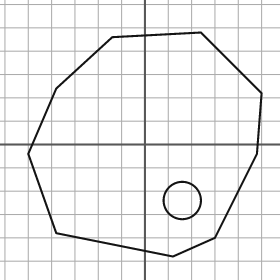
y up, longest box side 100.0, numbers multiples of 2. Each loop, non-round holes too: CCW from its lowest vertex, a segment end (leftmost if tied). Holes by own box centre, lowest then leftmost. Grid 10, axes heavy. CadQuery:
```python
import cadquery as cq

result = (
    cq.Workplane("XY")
    .moveTo(12.0, -48.0)
    .lineTo(30.0, -40.0)
    .lineTo(48.0, -4.0)
    .lineTo(50.0, 22.0)
    .lineTo(24.0, 48.0)
    .lineTo(-14.0, 46.0)
    .lineTo(-38.0, 24.0)
    .lineTo(-50.0, -4.0)
    .lineTo(-38.0, -38.0)
    .close()
    .moveTo(16.0, -24.0)
    .circle(8.0)
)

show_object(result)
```